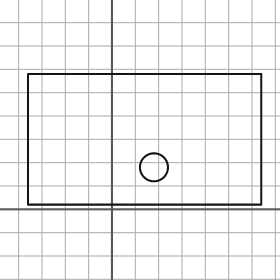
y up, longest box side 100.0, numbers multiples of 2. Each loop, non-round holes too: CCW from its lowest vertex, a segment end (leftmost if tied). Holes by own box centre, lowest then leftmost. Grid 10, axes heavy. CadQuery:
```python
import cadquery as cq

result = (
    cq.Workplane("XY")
    .moveTo(-36.0, 2.0)
    .lineTo(64.0, 2.0)
    .lineTo(64.0, 58.0)
    .lineTo(-36.0, 58.0)
    .close()
    .moveTo(18.0, 18.0)
    .circle(6.0)
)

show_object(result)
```